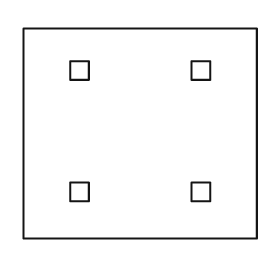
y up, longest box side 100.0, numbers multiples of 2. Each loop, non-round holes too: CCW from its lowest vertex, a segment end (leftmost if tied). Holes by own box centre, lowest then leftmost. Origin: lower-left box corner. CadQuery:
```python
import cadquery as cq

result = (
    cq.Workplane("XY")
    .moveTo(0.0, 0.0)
    .lineTo(100.0, 0.0)
    .lineTo(100.0, 90.0)
    .lineTo(0.0, 90.0)
    .close()
    .moveTo(20.0, 16.0)
    .lineTo(28.0, 16.0)
    .lineTo(28.0, 24.0)
    .lineTo(20.0, 24.0)
    .close()
    .moveTo(72.0, 16.0)
    .lineTo(80.0, 16.0)
    .lineTo(80.0, 24.0)
    .lineTo(72.0, 24.0)
    .close()
    .moveTo(20.0, 68.0)
    .lineTo(28.0, 68.0)
    .lineTo(28.0, 76.0)
    .lineTo(20.0, 76.0)
    .close()
    .moveTo(72.0, 68.0)
    .lineTo(80.0, 68.0)
    .lineTo(80.0, 76.0)
    .lineTo(72.0, 76.0)
    .close()
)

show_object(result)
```